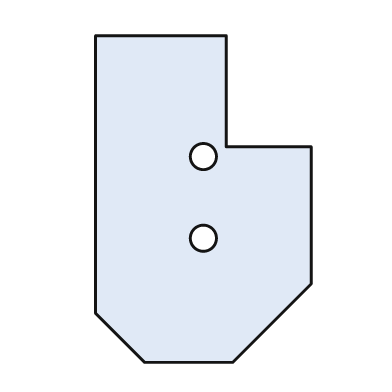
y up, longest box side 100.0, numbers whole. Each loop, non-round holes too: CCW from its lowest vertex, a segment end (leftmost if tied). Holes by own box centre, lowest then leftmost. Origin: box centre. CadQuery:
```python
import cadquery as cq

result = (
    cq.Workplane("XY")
    .moveTo(-18.0, -50.0)
    .lineTo(9.0, -50.0)
    .lineTo(33.0, -26.0)
    .lineTo(33.0, 16.0)
    .lineTo(7.0, 16.0)
    .lineTo(7.0, 50.0)
    .lineTo(-33.0, 50.0)
    .lineTo(-33.0, -35.0)
    .close()
    .moveTo(0.0, -12.0)
    .circle(4.0)
    .moveTo(0.0, 13.0)
    .circle(4.0)
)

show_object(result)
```